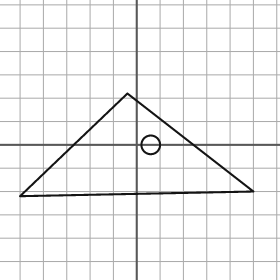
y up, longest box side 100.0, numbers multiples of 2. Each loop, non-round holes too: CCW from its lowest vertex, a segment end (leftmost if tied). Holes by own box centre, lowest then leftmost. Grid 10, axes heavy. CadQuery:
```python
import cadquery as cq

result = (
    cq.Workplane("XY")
    .moveTo(-50.0, -22.0)
    .lineTo(50.0, -20.0)
    .lineTo(-4.0, 22.0)
    .close()
    .moveTo(6.0, 0.0)
    .circle(4.0)
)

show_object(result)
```